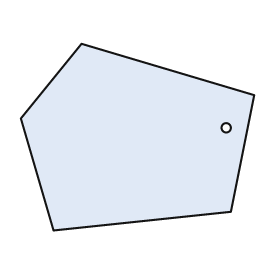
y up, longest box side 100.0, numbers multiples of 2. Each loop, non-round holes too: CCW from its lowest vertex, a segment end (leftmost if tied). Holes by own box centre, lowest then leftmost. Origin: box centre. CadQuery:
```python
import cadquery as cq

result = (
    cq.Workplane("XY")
    .moveTo(-36.0, -40.0)
    .lineTo(40.0, -32.0)
    .lineTo(50.0, 18.0)
    .lineTo(-24.0, 40.0)
    .lineTo(-50.0, 8.0)
    .close()
    .moveTo(38.0, 4.0)
    .circle(2.0)
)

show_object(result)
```